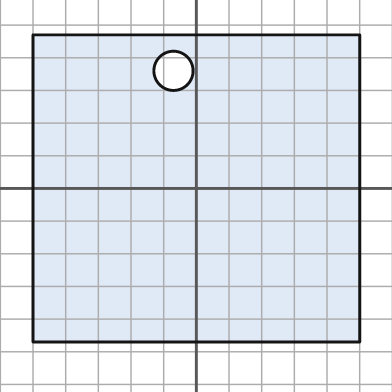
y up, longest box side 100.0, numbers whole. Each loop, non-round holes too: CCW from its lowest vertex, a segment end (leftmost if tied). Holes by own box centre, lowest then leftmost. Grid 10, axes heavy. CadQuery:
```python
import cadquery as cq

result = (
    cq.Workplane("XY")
    .moveTo(-50.0, -47.0)
    .lineTo(50.0, -47.0)
    .lineTo(50.0, 47.0)
    .lineTo(-50.0, 47.0)
    .close()
    .moveTo(-7.0, 36.0)
    .circle(6.0)
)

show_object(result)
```